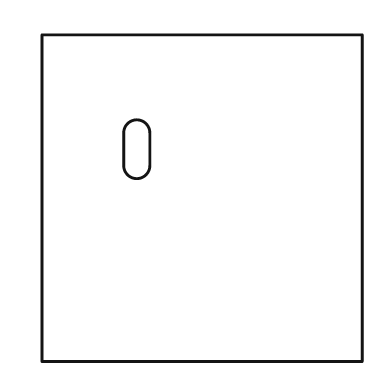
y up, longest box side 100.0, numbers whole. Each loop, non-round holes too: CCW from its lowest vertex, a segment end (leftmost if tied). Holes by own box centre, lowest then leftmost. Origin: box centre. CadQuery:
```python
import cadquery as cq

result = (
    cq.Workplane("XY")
    .moveTo(-49.0, -50.0)
    .lineTo(49.0, -50.0)
    .lineTo(49.0, 50.0)
    .lineTo(-49.0, 50.0)
    .close()
    .moveTo(-24.0, 10.0)
    .threePointArc((-20.0, 6.0), (-16.0, 10.0))
    .lineTo(-16.0, 20.0)
    .threePointArc((-20.0, 24.0), (-24.0, 20.0))
    .close()
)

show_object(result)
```